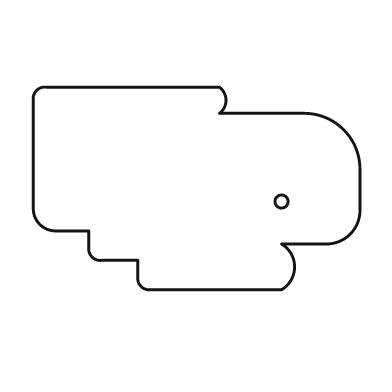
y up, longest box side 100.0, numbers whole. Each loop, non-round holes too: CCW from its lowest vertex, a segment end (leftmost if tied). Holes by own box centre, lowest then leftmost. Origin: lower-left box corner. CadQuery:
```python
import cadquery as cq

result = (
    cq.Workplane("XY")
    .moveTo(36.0, 0.0)
    .lineTo(76.0, 0.0)
    .threePointArc((80.0, 7.0), (76.0, 14.0))
    .lineTo(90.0, 14.0)
    .threePointArc((97.0, 17.0), (100.0, 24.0))
    .lineTo(100.0, 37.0)
    .threePointArc((95.0, 49.0), (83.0, 54.0))
    .lineTo(57.0, 54.0)
    .threePointArc((59.0, 58.0), (57.0, 62.0))
    .lineTo(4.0, 62.0)
    .threePointArc((1.0, 61.0), (0.0, 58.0))
    .lineTo(0.0, 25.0)
    .threePointArc((2.0, 20.0), (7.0, 18.0))
    .lineTo(17.0, 18.0)
    .lineTo(17.0, 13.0)
    .threePointArc((18.0, 10.0), (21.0, 9.0))
    .lineTo(32.0, 9.0)
    .lineTo(32.0, 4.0)
    .threePointArc((33.0, 1.0), (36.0, 0.0))
    .close()
    .moveTo(76.0, 27.0)
    .circle(2.0)
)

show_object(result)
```